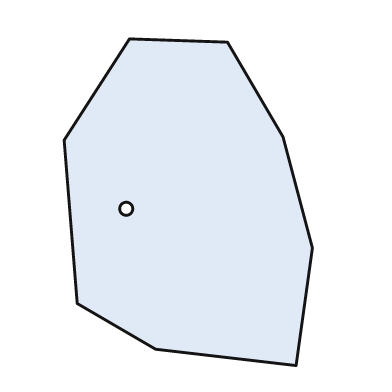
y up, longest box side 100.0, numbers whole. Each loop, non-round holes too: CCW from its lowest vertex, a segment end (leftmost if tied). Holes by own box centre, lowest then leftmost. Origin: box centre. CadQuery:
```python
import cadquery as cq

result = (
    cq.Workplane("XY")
    .moveTo(33.0, -50.0)
    .lineTo(38.0, -14.0)
    .lineTo(29.0, 20.0)
    .lineTo(12.0, 49.0)
    .lineTo(-18.0, 50.0)
    .lineTo(-38.0, 19.0)
    .lineTo(-34.0, -31.0)
    .lineTo(-10.0, -45.0)
    .close()
    .moveTo(-19.0, -2.0)
    .circle(2.0)
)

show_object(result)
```